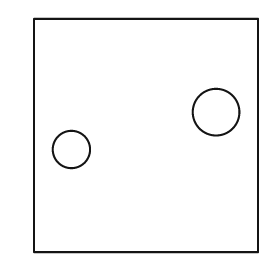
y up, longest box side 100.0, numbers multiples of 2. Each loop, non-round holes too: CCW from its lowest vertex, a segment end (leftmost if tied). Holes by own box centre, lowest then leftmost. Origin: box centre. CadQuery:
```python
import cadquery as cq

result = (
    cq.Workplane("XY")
    .moveTo(-48.0, -50.0)
    .lineTo(48.0, -50.0)
    .lineTo(48.0, 50.0)
    .lineTo(-48.0, 50.0)
    .close()
    .moveTo(-32.0, -6.0)
    .circle(8.0)
    .moveTo(30.0, 10.0)
    .circle(10.0)
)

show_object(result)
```